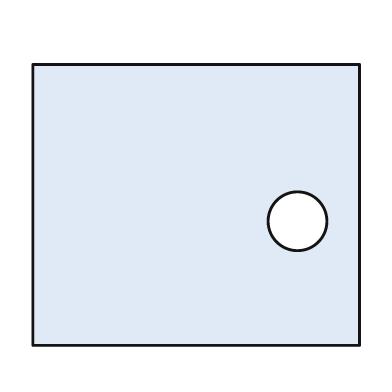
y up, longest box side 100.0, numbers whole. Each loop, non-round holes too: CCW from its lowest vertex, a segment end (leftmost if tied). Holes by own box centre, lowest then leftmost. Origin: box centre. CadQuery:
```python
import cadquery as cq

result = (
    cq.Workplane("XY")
    .moveTo(-50.0, -43.0)
    .lineTo(50.0, -43.0)
    .lineTo(50.0, 43.0)
    .lineTo(-50.0, 43.0)
    .close()
    .moveTo(31.0, -5.0)
    .circle(9.0)
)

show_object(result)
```